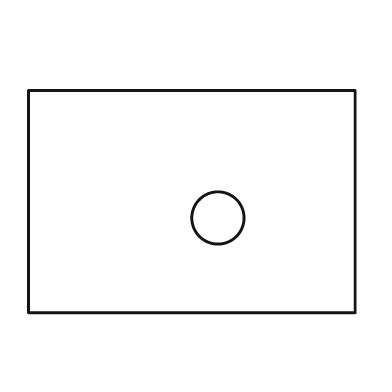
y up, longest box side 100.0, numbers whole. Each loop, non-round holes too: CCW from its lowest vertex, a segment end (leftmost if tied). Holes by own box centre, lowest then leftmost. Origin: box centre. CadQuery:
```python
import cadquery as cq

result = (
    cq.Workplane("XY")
    .moveTo(-50.0, -34.0)
    .lineTo(50.0, -34.0)
    .lineTo(50.0, 34.0)
    .lineTo(-50.0, 34.0)
    .close()
    .moveTo(8.0, -5.0)
    .circle(8.0)
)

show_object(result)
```